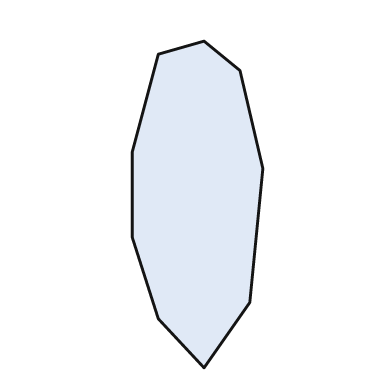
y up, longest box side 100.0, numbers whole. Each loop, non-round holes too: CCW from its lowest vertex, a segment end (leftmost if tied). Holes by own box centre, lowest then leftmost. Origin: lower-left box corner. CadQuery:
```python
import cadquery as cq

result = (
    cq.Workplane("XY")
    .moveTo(22.0, 0.0)
    .lineTo(36.0, 20.0)
    .lineTo(40.0, 61.0)
    .lineTo(33.0, 91.0)
    .lineTo(22.0, 100.0)
    .lineTo(8.0, 96.0)
    .lineTo(0.0, 66.0)
    .lineTo(0.0, 40.0)
    .lineTo(8.0, 15.0)
    .close()
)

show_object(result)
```